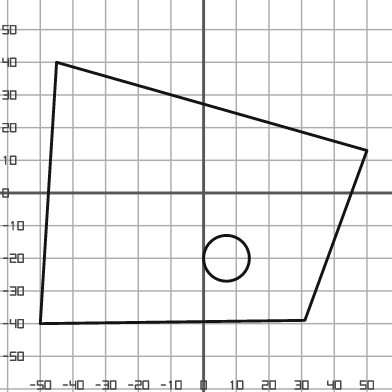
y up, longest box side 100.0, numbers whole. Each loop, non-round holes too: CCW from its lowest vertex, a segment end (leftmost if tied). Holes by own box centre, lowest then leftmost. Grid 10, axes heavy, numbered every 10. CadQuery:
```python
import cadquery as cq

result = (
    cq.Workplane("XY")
    .moveTo(-50.0, -40.0)
    .lineTo(31.0, -39.0)
    .lineTo(50.0, 13.0)
    .lineTo(-45.0, 40.0)
    .close()
    .moveTo(7.0, -20.0)
    .circle(7.0)
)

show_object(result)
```